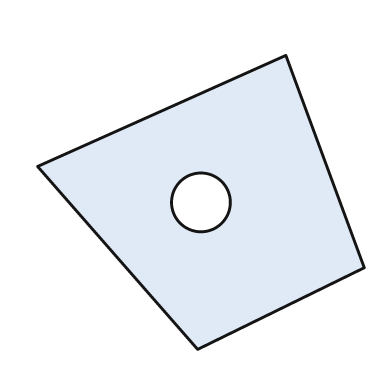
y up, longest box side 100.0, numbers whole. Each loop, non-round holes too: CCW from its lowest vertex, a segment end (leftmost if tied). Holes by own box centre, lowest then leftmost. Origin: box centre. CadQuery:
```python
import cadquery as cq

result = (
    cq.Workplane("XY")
    .moveTo(-1.0, -45.0)
    .lineTo(50.0, -20.0)
    .lineTo(26.0, 45.0)
    .lineTo(-50.0, 11.0)
    .close()
    .moveTo(0.0, 0.0)
    .circle(9.0)
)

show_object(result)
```